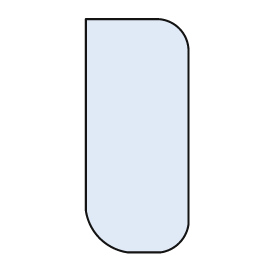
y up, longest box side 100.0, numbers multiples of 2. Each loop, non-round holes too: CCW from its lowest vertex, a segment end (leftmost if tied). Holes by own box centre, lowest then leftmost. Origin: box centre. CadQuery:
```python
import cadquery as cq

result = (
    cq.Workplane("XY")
    .moveTo(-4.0, -50.0)
    .lineTo(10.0, -50.0)
    .threePointArc((18.0, -46.0), (22.0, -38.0))
    .lineTo(22.0, 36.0)
    .threePointArc((18.0, 46.0), (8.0, 50.0))
    .lineTo(-22.0, 50.0)
    .lineTo(-22.0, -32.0)
    .threePointArc((-16.0, -44.0), (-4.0, -50.0))
    .close()
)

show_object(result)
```